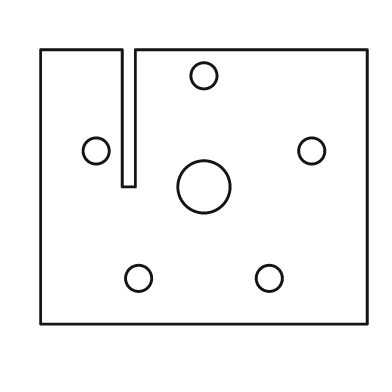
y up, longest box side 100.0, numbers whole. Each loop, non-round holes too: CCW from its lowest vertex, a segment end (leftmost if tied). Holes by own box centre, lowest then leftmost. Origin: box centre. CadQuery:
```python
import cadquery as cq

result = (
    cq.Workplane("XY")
    .moveTo(-50.0, -42.0)
    .lineTo(50.0, -42.0)
    .lineTo(50.0, 42.0)
    .lineTo(-21.0, 42.0)
    .lineTo(-21.0, 0.0)
    .lineTo(-25.0, 0.0)
    .lineTo(-25.0, 42.0)
    .lineTo(-50.0, 42.0)
    .close()
    .moveTo(-20.0, -28.0)
    .circle(4.0)
    .moveTo(20.0, -28.0)
    .circle(4.0)
    .moveTo(0.0, 0.0)
    .circle(8.0)
    .moveTo(-33.0, 11.0)
    .circle(4.0)
    .moveTo(33.0, 11.0)
    .circle(4.0)
    .moveTo(0.0, 34.0)
    .circle(4.0)
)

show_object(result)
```